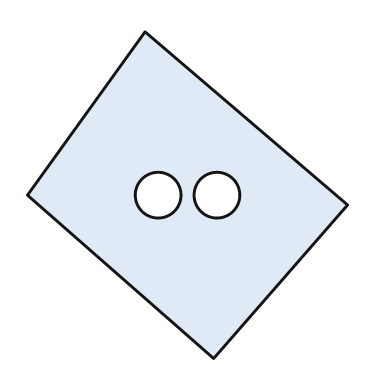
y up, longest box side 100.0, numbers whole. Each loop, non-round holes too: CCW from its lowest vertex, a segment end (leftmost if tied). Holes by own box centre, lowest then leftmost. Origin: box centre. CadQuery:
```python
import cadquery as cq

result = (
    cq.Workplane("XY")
    .moveTo(8.0, -50.0)
    .lineTo(49.0, -3.0)
    .lineTo(-13.0, 50.0)
    .lineTo(-49.0, 0.0)
    .close()
    .moveTo(-9.0, 0.0)
    .circle(7.0)
    .moveTo(9.0, 0.0)
    .circle(7.0)
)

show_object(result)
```